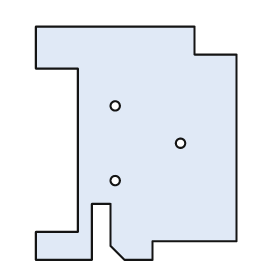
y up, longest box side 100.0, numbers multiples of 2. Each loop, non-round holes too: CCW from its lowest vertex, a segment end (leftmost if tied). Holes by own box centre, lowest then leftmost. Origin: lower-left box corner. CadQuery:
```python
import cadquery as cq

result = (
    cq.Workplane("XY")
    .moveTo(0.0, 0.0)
    .lineTo(24.0, 0.0)
    .lineTo(24.0, 24.0)
    .lineTo(32.0, 24.0)
    .lineTo(32.0, 6.0)
    .lineTo(38.0, 0.0)
    .lineTo(50.0, 0.0)
    .lineTo(50.0, 8.0)
    .lineTo(86.0, 8.0)
    .lineTo(86.0, 88.0)
    .lineTo(68.0, 88.0)
    .lineTo(68.0, 100.0)
    .lineTo(0.0, 100.0)
    .lineTo(0.0, 82.0)
    .lineTo(18.0, 82.0)
    .lineTo(18.0, 12.0)
    .lineTo(0.0, 12.0)
    .close()
    .moveTo(34.0, 34.0)
    .circle(2.0)
    .moveTo(62.0, 50.0)
    .circle(2.0)
    .moveTo(34.0, 66.0)
    .circle(2.0)
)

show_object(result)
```